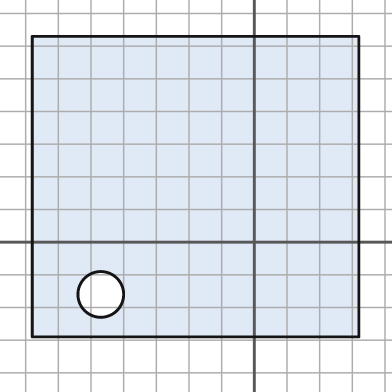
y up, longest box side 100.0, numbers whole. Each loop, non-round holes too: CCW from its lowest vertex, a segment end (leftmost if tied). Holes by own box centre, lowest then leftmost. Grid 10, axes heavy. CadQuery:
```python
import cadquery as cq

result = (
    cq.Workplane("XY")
    .moveTo(-68.0, -29.0)
    .lineTo(32.0, -29.0)
    .lineTo(32.0, 63.0)
    .lineTo(-68.0, 63.0)
    .close()
    .moveTo(-47.0, -16.0)
    .circle(7.0)
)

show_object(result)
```